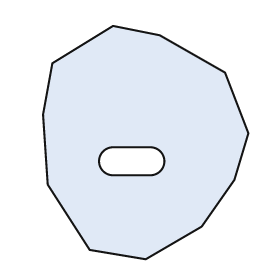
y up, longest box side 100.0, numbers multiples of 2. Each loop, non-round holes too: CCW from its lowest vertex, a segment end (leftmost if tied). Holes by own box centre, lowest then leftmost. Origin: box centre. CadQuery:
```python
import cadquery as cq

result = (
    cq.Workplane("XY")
    .moveTo(0.0, -50.0)
    .lineTo(24.0, -36.0)
    .lineTo(38.0, -16.0)
    .lineTo(44.0, 4.0)
    .lineTo(34.0, 30.0)
    .lineTo(6.0, 46.0)
    .lineTo(-14.0, 50.0)
    .lineTo(-40.0, 34.0)
    .lineTo(-44.0, 12.0)
    .lineTo(-42.0, -18.0)
    .lineTo(-24.0, -46.0)
    .close()
    .moveTo(-14.0, -14.0)
    .lineTo(2.0, -14.0)
    .threePointArc((8.0, -8.0), (2.0, -2.0))
    .lineTo(-14.0, -2.0)
    .threePointArc((-20.0, -8.0), (-14.0, -14.0))
    .close()
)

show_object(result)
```